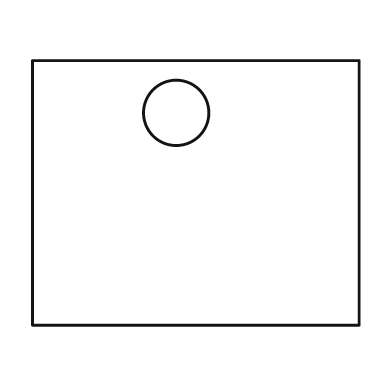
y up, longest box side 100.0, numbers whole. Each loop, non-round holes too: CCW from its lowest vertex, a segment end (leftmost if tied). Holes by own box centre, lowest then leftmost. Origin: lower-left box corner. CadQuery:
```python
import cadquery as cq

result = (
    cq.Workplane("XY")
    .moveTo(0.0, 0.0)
    .lineTo(100.0, 0.0)
    .lineTo(100.0, 81.0)
    .lineTo(0.0, 81.0)
    .close()
    .moveTo(44.0, 65.0)
    .circle(10.0)
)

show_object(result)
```